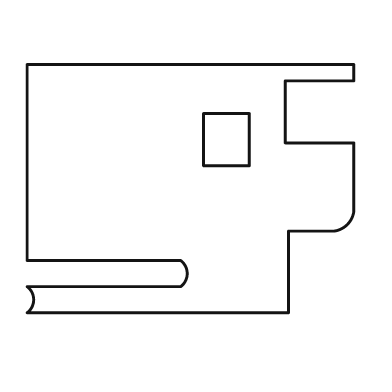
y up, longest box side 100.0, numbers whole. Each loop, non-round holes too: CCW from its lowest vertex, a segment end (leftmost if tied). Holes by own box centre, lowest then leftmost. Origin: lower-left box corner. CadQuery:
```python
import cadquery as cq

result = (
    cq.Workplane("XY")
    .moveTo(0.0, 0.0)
    .lineTo(80.0, 0.0)
    .lineTo(80.0, 25.0)
    .lineTo(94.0, 25.0)
    .threePointArc((98.0, 27.0), (100.0, 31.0))
    .lineTo(100.0, 52.0)
    .lineTo(79.0, 52.0)
    .lineTo(79.0, 71.0)
    .lineTo(100.0, 71.0)
    .lineTo(100.0, 76.0)
    .lineTo(0.0, 76.0)
    .lineTo(0.0, 16.0)
    .lineTo(47.0, 16.0)
    .threePointArc((49.0, 12.0), (47.0, 8.0))
    .lineTo(0.0, 8.0)
    .threePointArc((2.0, 4.0), (0.0, 0.0))
    .close()
    .moveTo(54.0, 45.0)
    .lineTo(68.0, 45.0)
    .lineTo(68.0, 61.0)
    .lineTo(54.0, 61.0)
    .close()
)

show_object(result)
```